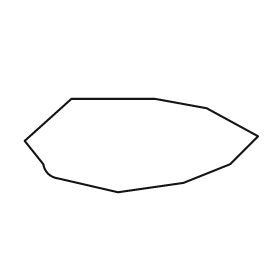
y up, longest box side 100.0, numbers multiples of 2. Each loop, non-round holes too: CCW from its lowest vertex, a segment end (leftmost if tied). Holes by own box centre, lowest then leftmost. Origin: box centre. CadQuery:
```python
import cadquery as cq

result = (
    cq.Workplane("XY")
    .moveTo(-10.0, -20.0)
    .lineTo(18.0, -16.0)
    .lineTo(38.0, -8.0)
    .lineTo(50.0, 4.0)
    .lineTo(28.0, 16.0)
    .lineTo(6.0, 20.0)
    .lineTo(-30.0, 20.0)
    .lineTo(-50.0, 2.0)
    .lineTo(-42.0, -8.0)
    .threePointArc((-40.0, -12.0), (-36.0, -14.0))
    .close()
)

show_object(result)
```